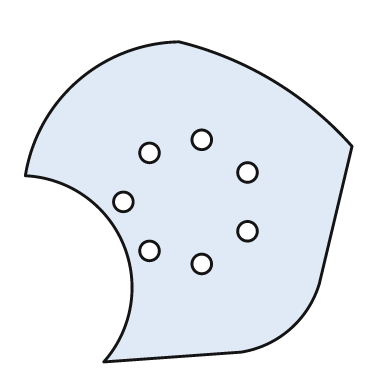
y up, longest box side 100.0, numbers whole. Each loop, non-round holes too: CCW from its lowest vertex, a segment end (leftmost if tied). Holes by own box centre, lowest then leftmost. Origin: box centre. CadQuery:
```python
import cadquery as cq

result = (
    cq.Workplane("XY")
    .moveTo(-26.0, -49.0)
    .lineTo(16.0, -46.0)
    .threePointArc((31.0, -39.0), (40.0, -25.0))
    .lineTo(50.0, 17.0)
    .threePointArc((26.0, 37.0), (-3.0, 49.0))
    .threePointArc((-34.0, 37.0), (-50.0, 8.0))
    .threePointArc((-20.0, -13.0), (-26.0, -49.0))
    .close()
    .moveTo(4.0, -19.0)
    .circle(3.0)
    .moveTo(-12.0, -15.0)
    .circle(3.0)
    .moveTo(18.0, -9.0)
    .circle(3.0)
    .moveTo(-20.0, 0.0)
    .circle(3.0)
    .moveTo(18.0, 9.0)
    .circle(3.0)
    .moveTo(-12.0, 15.0)
    .circle(3.0)
    .moveTo(4.0, 19.0)
    .circle(3.0)
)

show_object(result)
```